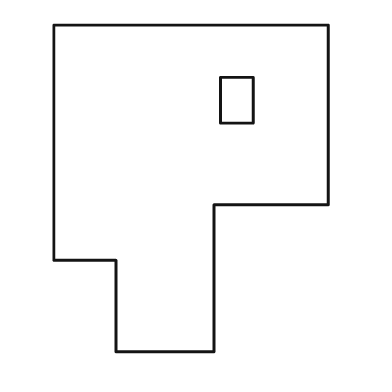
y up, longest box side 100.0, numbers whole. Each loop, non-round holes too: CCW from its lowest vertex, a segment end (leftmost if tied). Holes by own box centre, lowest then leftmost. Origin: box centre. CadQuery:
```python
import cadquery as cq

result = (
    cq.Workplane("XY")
    .moveTo(-23.0, -50.0)
    .lineTo(7.0, -50.0)
    .lineTo(7.0, -5.0)
    .lineTo(42.0, -5.0)
    .lineTo(42.0, 50.0)
    .lineTo(-42.0, 50.0)
    .lineTo(-42.0, -22.0)
    .lineTo(-23.0, -22.0)
    .close()
    .moveTo(9.0, 20.0)
    .lineTo(19.0, 20.0)
    .lineTo(19.0, 34.0)
    .lineTo(9.0, 34.0)
    .close()
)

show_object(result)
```